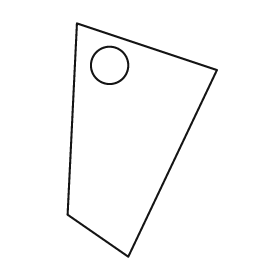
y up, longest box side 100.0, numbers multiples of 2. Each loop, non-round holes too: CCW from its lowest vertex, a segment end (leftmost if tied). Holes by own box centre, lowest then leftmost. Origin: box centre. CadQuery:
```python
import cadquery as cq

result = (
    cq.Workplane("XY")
    .moveTo(-6.0, -50.0)
    .lineTo(32.0, 30.0)
    .lineTo(-28.0, 50.0)
    .lineTo(-32.0, -32.0)
    .close()
    .moveTo(-14.0, 32.0)
    .circle(8.0)
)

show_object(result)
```